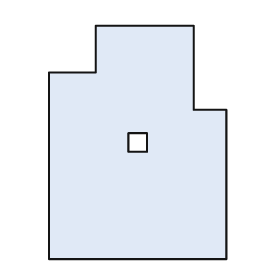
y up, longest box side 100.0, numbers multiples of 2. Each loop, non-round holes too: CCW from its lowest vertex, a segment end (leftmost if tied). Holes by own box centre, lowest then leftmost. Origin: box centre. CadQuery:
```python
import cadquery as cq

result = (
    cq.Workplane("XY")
    .moveTo(-38.0, -50.0)
    .lineTo(38.0, -50.0)
    .lineTo(38.0, 14.0)
    .lineTo(24.0, 14.0)
    .lineTo(24.0, 50.0)
    .lineTo(-18.0, 50.0)
    .lineTo(-18.0, 30.0)
    .lineTo(-38.0, 30.0)
    .close()
    .moveTo(-4.0, -4.0)
    .lineTo(4.0, -4.0)
    .lineTo(4.0, 4.0)
    .lineTo(-4.0, 4.0)
    .close()
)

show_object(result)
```